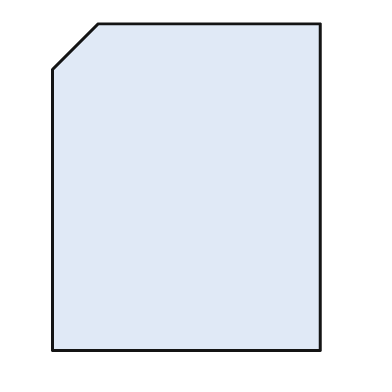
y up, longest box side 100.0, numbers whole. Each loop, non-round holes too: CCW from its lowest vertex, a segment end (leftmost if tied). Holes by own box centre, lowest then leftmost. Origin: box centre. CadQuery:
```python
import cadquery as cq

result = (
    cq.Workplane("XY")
    .moveTo(-41.0, -50.0)
    .lineTo(41.0, -50.0)
    .lineTo(41.0, 50.0)
    .lineTo(-27.0, 50.0)
    .lineTo(-41.0, 36.0)
    .close()
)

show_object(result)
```